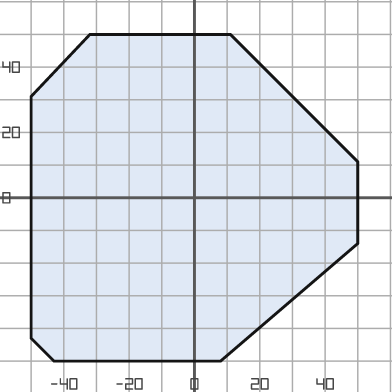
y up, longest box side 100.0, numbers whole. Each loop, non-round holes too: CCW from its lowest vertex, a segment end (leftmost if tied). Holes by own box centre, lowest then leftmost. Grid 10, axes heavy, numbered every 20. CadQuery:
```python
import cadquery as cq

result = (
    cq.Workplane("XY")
    .moveTo(-43.0, -50.0)
    .lineTo(8.0, -50.0)
    .lineTo(50.0, -14.0)
    .lineTo(50.0, 11.0)
    .lineTo(11.0, 50.0)
    .lineTo(-32.0, 50.0)
    .lineTo(-50.0, 31.0)
    .lineTo(-50.0, -43.0)
    .close()
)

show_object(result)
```